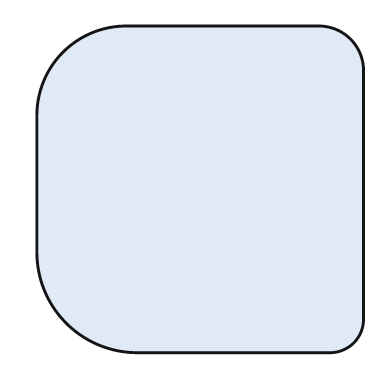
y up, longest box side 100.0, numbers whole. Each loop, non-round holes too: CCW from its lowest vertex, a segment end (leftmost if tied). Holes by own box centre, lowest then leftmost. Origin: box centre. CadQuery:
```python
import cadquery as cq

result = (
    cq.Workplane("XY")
    .moveTo(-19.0, -50.0)
    .lineTo(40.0, -50.0)
    .threePointArc((47.0, -47.0), (50.0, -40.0))
    .lineTo(50.0, 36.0)
    .threePointArc((46.0, 46.0), (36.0, 50.0))
    .lineTo(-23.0, 50.0)
    .threePointArc((-42.0, 42.0), (-50.0, 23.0))
    .lineTo(-50.0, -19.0)
    .threePointArc((-41.0, -41.0), (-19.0, -50.0))
    .close()
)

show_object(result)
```